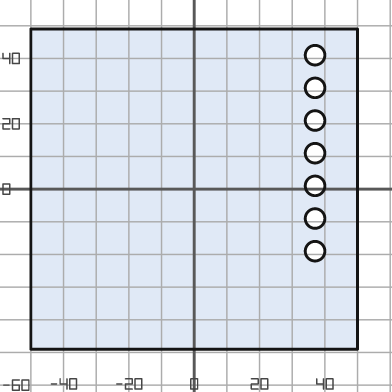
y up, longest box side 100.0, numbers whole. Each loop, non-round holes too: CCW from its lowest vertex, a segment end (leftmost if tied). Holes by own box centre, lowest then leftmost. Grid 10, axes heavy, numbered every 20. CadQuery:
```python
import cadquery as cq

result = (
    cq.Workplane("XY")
    .moveTo(-50.0, -49.0)
    .lineTo(50.0, -49.0)
    .lineTo(50.0, 49.0)
    .lineTo(-50.0, 49.0)
    .close()
    .moveTo(37.0, -19.0)
    .circle(3.0)
    .moveTo(37.0, -9.0)
    .circle(3.0)
    .moveTo(37.0, 1.0)
    .circle(3.0)
    .moveTo(37.0, 11.0)
    .circle(3.0)
    .moveTo(37.0, 21.0)
    .circle(3.0)
    .moveTo(37.0, 31.0)
    .circle(3.0)
    .moveTo(37.0, 41.0)
    .circle(3.0)
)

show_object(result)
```